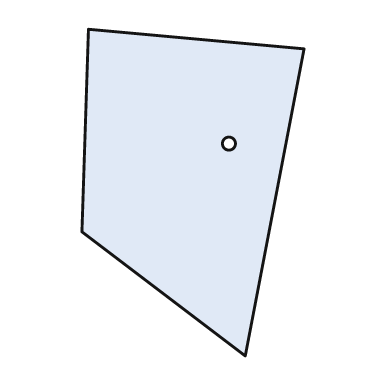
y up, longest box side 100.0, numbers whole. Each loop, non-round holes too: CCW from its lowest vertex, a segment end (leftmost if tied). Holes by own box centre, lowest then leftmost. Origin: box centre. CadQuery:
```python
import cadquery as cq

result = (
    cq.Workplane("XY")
    .moveTo(16.0, -50.0)
    .lineTo(34.0, 44.0)
    .lineTo(-32.0, 50.0)
    .lineTo(-34.0, -12.0)
    .close()
    .moveTo(11.0, 15.0)
    .circle(2.0)
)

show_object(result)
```